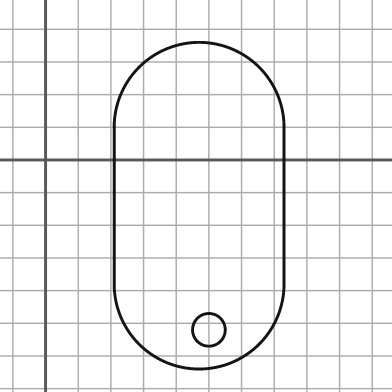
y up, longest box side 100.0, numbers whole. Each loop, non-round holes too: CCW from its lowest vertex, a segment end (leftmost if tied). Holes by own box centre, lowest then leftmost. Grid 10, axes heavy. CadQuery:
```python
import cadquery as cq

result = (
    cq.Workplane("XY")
    .moveTo(21.0, -38.0)
    .threePointArc((47.0, -64.0), (73.0, -38.0))
    .lineTo(73.0, 10.0)
    .threePointArc((47.0, 36.0), (21.0, 10.0))
    .close()
    .moveTo(50.0, -52.0)
    .circle(5.0)
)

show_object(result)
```